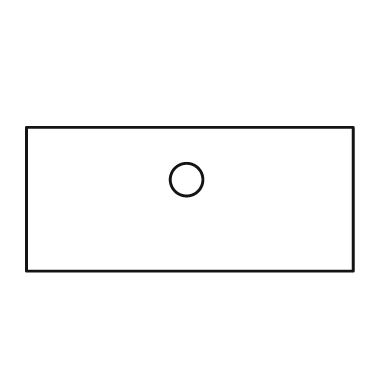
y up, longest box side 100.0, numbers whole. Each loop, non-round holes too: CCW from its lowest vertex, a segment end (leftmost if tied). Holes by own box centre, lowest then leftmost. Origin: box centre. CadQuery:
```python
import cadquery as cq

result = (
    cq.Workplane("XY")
    .moveTo(-50.0, -22.0)
    .lineTo(50.0, -22.0)
    .lineTo(50.0, 22.0)
    .lineTo(-50.0, 22.0)
    .close()
    .moveTo(-1.0, 6.0)
    .circle(5.0)
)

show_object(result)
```